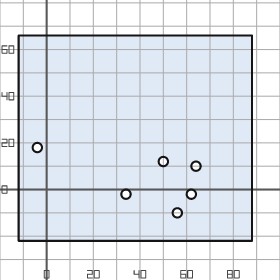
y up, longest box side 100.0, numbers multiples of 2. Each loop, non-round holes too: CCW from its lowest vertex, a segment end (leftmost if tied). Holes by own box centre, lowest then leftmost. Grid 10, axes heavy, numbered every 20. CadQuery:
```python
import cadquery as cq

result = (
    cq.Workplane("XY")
    .moveTo(-12.0, -22.0)
    .lineTo(88.0, -22.0)
    .lineTo(88.0, 66.0)
    .lineTo(-12.0, 66.0)
    .close()
    .moveTo(56.0, -10.0)
    .circle(2.0)
    .moveTo(34.0, -2.0)
    .circle(2.0)
    .moveTo(62.0, -2.0)
    .circle(2.0)
    .moveTo(64.0, 10.0)
    .circle(2.0)
    .moveTo(50.0, 12.0)
    .circle(2.0)
    .moveTo(-4.0, 18.0)
    .circle(2.0)
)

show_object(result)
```